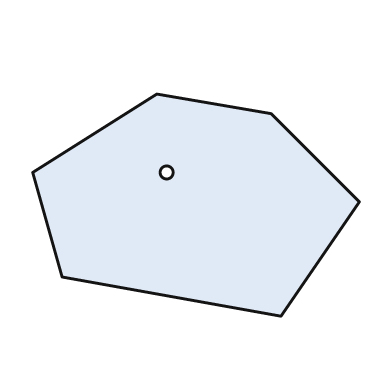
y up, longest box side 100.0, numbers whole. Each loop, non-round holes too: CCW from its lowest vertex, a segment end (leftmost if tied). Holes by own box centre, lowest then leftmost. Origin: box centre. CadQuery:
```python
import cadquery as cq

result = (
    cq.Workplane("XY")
    .moveTo(26.0, -34.0)
    .lineTo(50.0, 1.0)
    .lineTo(23.0, 28.0)
    .lineTo(-12.0, 34.0)
    .lineTo(-50.0, 10.0)
    .lineTo(-41.0, -22.0)
    .close()
    .moveTo(-9.0, 10.0)
    .circle(2.0)
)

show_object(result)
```